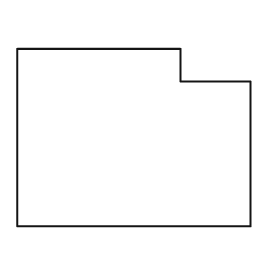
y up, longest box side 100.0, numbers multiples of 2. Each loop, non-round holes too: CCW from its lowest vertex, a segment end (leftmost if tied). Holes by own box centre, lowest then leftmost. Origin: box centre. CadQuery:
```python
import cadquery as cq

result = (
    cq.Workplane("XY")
    .moveTo(-50.0, -38.0)
    .lineTo(50.0, -38.0)
    .lineTo(50.0, 24.0)
    .lineTo(20.0, 24.0)
    .lineTo(20.0, 38.0)
    .lineTo(-50.0, 38.0)
    .close()
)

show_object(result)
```